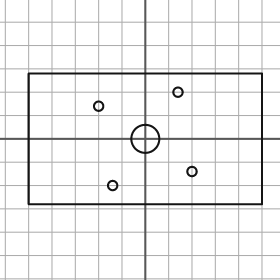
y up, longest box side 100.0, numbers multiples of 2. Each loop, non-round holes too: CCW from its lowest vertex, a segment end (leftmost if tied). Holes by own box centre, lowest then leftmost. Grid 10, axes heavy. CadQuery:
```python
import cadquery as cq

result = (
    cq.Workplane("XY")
    .moveTo(-50.0, -28.0)
    .lineTo(50.0, -28.0)
    .lineTo(50.0, 28.0)
    .lineTo(-50.0, 28.0)
    .close()
    .moveTo(-14.0, -20.0)
    .circle(2.0)
    .moveTo(20.0, -14.0)
    .circle(2.0)
    .moveTo(0.0, 0.0)
    .circle(6.0)
    .moveTo(-20.0, 14.0)
    .circle(2.0)
    .moveTo(14.0, 20.0)
    .circle(2.0)
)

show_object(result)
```